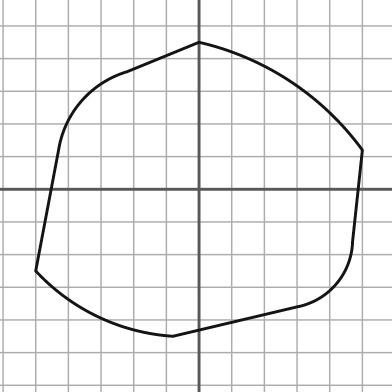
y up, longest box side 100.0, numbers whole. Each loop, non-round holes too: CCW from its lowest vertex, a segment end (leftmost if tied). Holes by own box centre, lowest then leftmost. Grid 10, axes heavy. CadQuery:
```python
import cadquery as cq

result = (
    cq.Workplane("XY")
    .moveTo(-8.0, -45.0)
    .lineTo(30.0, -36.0)
    .threePointArc((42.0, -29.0), (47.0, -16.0))
    .lineTo(50.0, 12.0)
    .threePointArc((28.0, 33.0), (0.0, 45.0))
    .lineTo(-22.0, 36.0)
    .threePointArc((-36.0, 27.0), (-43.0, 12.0))
    .lineTo(-50.0, -25.0)
    .threePointArc((-31.0, -39.0), (-8.0, -45.0))
    .close()
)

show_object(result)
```